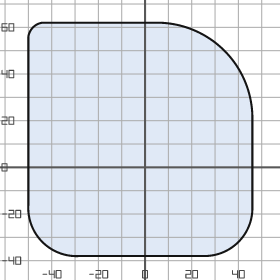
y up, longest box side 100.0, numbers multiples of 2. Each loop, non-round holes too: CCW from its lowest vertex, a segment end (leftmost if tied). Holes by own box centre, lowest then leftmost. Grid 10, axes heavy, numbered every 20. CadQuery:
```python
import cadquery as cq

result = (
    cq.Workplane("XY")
    .moveTo(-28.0, -38.0)
    .lineTo(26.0, -38.0)
    .threePointArc((40.0, -32.0), (46.0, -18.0))
    .lineTo(46.0, 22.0)
    .threePointArc((34.0, 50.0), (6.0, 62.0))
    .lineTo(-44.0, 62.0)
    .threePointArc((-48.0, 60.0), (-50.0, 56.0))
    .lineTo(-50.0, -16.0)
    .threePointArc((-44.0, -32.0), (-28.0, -38.0))
    .close()
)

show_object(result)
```